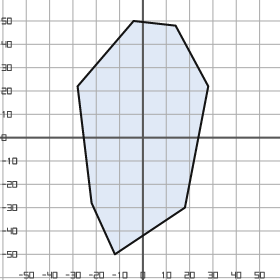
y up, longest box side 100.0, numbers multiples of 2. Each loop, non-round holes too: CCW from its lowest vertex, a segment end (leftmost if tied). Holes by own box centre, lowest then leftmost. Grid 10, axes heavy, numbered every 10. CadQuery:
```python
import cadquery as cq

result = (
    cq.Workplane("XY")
    .moveTo(-12.0, -50.0)
    .lineTo(18.0, -30.0)
    .lineTo(28.0, 22.0)
    .lineTo(14.0, 48.0)
    .lineTo(-4.0, 50.0)
    .lineTo(-28.0, 22.0)
    .lineTo(-22.0, -28.0)
    .close()
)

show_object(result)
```